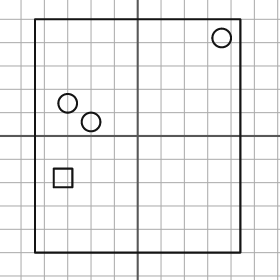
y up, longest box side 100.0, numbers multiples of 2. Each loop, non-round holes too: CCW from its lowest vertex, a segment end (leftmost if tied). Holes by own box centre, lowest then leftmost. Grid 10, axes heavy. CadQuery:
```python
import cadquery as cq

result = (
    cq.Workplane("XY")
    .moveTo(-44.0, -50.0)
    .lineTo(44.0, -50.0)
    .lineTo(44.0, 50.0)
    .lineTo(-44.0, 50.0)
    .close()
    .moveTo(-36.0, -22.0)
    .lineTo(-28.0, -22.0)
    .lineTo(-28.0, -14.0)
    .lineTo(-36.0, -14.0)
    .close()
    .moveTo(-20.0, 6.0)
    .circle(4.0)
    .moveTo(-30.0, 14.0)
    .circle(4.0)
    .moveTo(36.0, 42.0)
    .circle(4.0)
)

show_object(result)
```